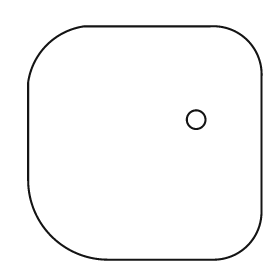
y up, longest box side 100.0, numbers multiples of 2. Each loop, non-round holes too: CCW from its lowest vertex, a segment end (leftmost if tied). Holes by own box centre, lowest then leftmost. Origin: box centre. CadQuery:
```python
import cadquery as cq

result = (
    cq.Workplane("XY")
    .moveTo(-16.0, -50.0)
    .lineTo(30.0, -50.0)
    .threePointArc((44.0, -44.0), (50.0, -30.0))
    .lineTo(50.0, 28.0)
    .threePointArc((44.0, 44.0), (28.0, 50.0))
    .lineTo(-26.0, 50.0)
    .threePointArc((-42.0, 42.0), (-50.0, 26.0))
    .lineTo(-50.0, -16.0)
    .threePointArc((-40.0, -40.0), (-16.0, -50.0))
    .close()
    .moveTo(22.0, 10.0)
    .circle(4.0)
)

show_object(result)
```